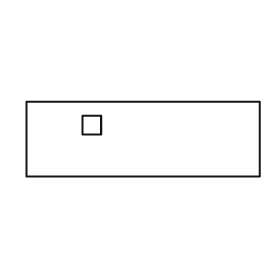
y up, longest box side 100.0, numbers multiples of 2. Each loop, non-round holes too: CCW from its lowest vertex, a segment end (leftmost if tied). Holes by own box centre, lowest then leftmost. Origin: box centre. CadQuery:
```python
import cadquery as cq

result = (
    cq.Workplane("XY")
    .moveTo(-50.0, -16.0)
    .lineTo(50.0, -16.0)
    .lineTo(50.0, 16.0)
    .lineTo(-50.0, 16.0)
    .close()
    .moveTo(-26.0, 2.0)
    .lineTo(-18.0, 2.0)
    .lineTo(-18.0, 10.0)
    .lineTo(-26.0, 10.0)
    .close()
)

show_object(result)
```